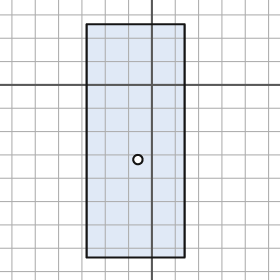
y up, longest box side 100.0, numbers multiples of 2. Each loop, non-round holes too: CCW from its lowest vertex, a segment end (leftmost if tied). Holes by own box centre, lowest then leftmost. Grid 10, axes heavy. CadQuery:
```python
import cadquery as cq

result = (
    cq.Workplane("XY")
    .moveTo(-28.0, -74.0)
    .lineTo(14.0, -74.0)
    .lineTo(14.0, 26.0)
    .lineTo(-28.0, 26.0)
    .close()
    .moveTo(-6.0, -32.0)
    .circle(2.0)
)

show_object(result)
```